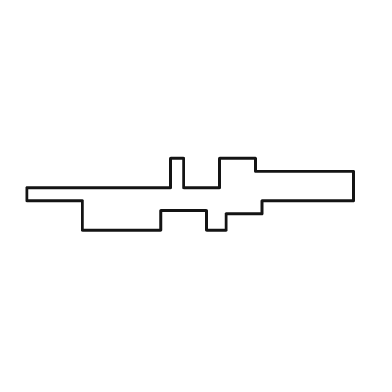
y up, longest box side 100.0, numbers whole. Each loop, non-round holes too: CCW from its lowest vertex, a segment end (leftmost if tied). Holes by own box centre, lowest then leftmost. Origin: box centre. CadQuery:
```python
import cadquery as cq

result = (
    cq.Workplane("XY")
    .moveTo(-33.0, -11.0)
    .lineTo(-9.0, -11.0)
    .lineTo(-9.0, -5.0)
    .lineTo(5.0, -5.0)
    .lineTo(5.0, -11.0)
    .lineTo(11.0, -11.0)
    .lineTo(11.0, -6.0)
    .lineTo(22.0, -6.0)
    .lineTo(22.0, -2.0)
    .lineTo(50.0, -2.0)
    .lineTo(50.0, 7.0)
    .lineTo(20.0, 7.0)
    .lineTo(20.0, 11.0)
    .lineTo(9.0, 11.0)
    .lineTo(9.0, 2.0)
    .lineTo(-2.0, 2.0)
    .lineTo(-2.0, 11.0)
    .lineTo(-6.0, 11.0)
    .lineTo(-6.0, 2.0)
    .lineTo(-50.0, 2.0)
    .lineTo(-50.0, -2.0)
    .lineTo(-33.0, -2.0)
    .close()
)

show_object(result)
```